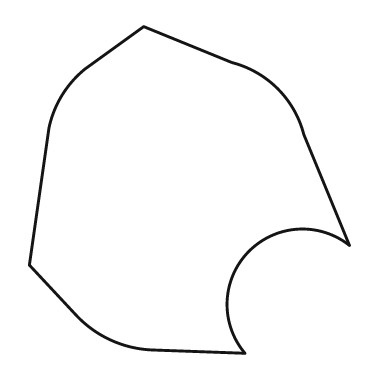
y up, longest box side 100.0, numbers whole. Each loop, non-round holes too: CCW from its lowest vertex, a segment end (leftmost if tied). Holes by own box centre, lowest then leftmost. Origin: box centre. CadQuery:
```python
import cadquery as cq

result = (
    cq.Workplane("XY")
    .moveTo(17.0, -50.0)
    .threePointArc((18.0, -19.0), (49.0, -17.0))
    .lineTo(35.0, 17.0)
    .threePointArc((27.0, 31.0), (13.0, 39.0))
    .lineTo(-14.0, 50.0)
    .lineTo(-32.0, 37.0)
    .threePointArc((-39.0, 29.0), (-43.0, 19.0))
    .lineTo(-49.0, -23.0)
    .lineTo(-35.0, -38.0)
    .threePointArc((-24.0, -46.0), (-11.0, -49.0))
    .close()
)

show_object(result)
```